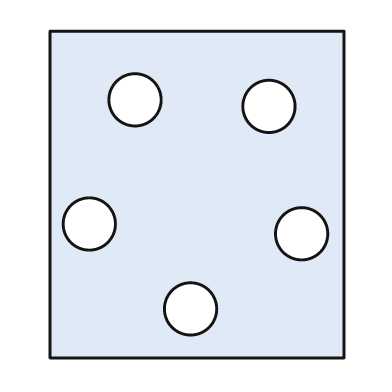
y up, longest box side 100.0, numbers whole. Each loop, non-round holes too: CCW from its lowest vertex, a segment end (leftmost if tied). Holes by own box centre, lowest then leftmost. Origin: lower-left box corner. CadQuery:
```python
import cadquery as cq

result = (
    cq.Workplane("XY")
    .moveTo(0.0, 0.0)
    .lineTo(90.0, 0.0)
    .lineTo(90.0, 100.0)
    .lineTo(0.0, 100.0)
    .close()
    .moveTo(43.0, 15.0)
    .circle(8.0)
    .moveTo(77.0, 38.0)
    .circle(8.0)
    .moveTo(12.0, 41.0)
    .circle(8.0)
    .moveTo(67.0, 77.0)
    .circle(8.0)
    .moveTo(26.0, 79.0)
    .circle(8.0)
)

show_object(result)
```